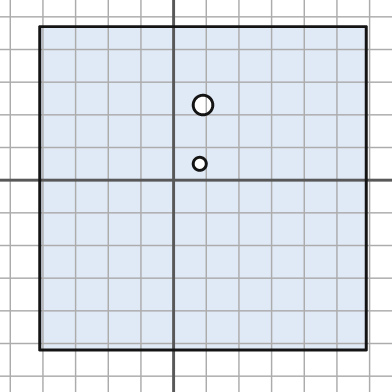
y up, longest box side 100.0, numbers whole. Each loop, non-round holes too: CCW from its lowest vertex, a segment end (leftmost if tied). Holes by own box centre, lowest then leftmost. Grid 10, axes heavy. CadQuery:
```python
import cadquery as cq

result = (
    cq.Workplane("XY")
    .moveTo(-41.0, -52.0)
    .lineTo(59.0, -52.0)
    .lineTo(59.0, 47.0)
    .lineTo(-41.0, 47.0)
    .close()
    .moveTo(8.0, 5.0)
    .circle(2.0)
    .moveTo(9.0, 23.0)
    .circle(3.0)
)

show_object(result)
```